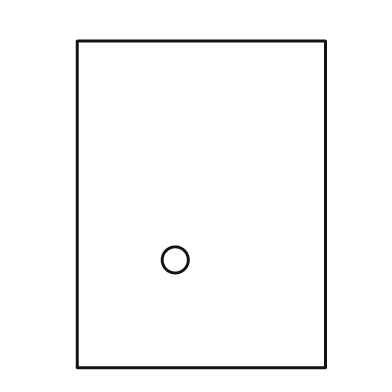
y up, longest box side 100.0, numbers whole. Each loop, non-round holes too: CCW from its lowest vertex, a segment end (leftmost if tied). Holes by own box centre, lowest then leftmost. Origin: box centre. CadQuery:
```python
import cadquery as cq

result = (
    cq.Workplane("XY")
    .moveTo(-38.0, -50.0)
    .lineTo(38.0, -50.0)
    .lineTo(38.0, 50.0)
    .lineTo(-38.0, 50.0)
    .close()
    .moveTo(-8.0, -17.0)
    .circle(4.0)
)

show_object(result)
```